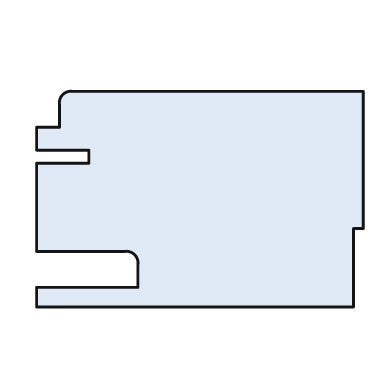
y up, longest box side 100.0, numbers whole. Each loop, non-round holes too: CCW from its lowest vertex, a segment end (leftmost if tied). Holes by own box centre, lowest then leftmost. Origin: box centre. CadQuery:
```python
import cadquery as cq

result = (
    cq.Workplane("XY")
    .moveTo(-50.0, -33.0)
    .lineTo(47.0, -33.0)
    .lineTo(47.0, -9.0)
    .lineTo(50.0, -9.0)
    .lineTo(50.0, 33.0)
    .lineTo(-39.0, 33.0)
    .threePointArc((-42.0, 32.0), (-43.0, 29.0))
    .lineTo(-43.0, 22.0)
    .lineTo(-50.0, 22.0)
    .lineTo(-50.0, 15.0)
    .lineTo(-34.0, 15.0)
    .lineTo(-34.0, 11.0)
    .lineTo(-50.0, 11.0)
    .lineTo(-50.0, -16.0)
    .lineTo(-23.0, -16.0)
    .threePointArc((-20.0, -17.0), (-19.0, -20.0))
    .lineTo(-19.0, -27.0)
    .lineTo(-50.0, -27.0)
    .close()
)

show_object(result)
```